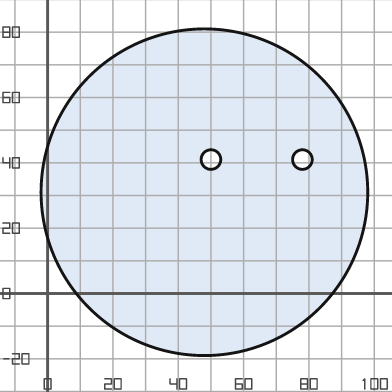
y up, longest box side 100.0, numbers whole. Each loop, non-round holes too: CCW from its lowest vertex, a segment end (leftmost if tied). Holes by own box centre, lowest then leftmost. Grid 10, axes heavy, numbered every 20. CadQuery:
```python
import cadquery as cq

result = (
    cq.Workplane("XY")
    .moveTo(48.0, 31.0)
    .circle(50.0)
    .moveTo(50.0, 41.0)
    .circle(3.0)
    .moveTo(78.0, 41.0)
    .circle(3.0)
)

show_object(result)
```